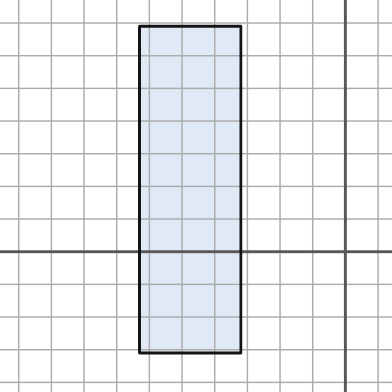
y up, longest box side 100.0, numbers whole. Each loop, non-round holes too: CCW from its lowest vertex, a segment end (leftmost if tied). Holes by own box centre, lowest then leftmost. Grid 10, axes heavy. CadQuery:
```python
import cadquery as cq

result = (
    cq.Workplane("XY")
    .moveTo(-63.0, -31.0)
    .lineTo(-32.0, -31.0)
    .lineTo(-32.0, 69.0)
    .lineTo(-63.0, 69.0)
    .close()
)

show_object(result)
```